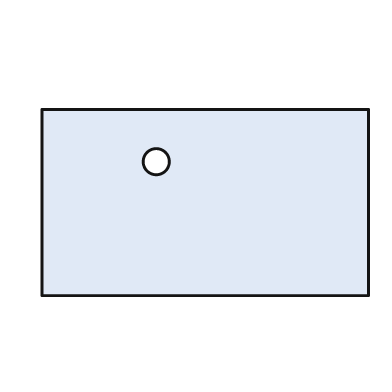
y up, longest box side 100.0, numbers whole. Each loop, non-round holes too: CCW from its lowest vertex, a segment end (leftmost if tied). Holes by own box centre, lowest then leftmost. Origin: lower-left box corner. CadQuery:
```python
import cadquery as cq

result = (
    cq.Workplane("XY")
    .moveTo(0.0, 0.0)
    .lineTo(100.0, 0.0)
    .lineTo(100.0, 57.0)
    .lineTo(0.0, 57.0)
    .close()
    .moveTo(35.0, 41.0)
    .circle(4.0)
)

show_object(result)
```